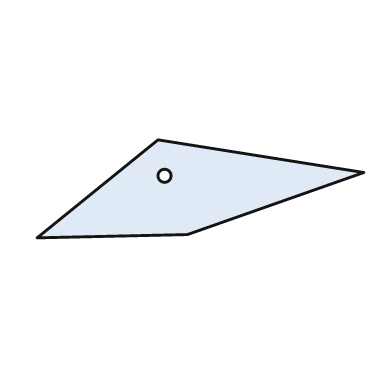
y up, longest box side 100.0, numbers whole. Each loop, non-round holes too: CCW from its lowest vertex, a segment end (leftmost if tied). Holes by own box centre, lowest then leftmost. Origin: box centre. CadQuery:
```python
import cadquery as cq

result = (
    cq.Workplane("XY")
    .moveTo(-50.0, -15.0)
    .lineTo(-4.0, -14.0)
    .lineTo(50.0, 5.0)
    .lineTo(-13.0, 15.0)
    .close()
    .moveTo(-11.0, 4.0)
    .circle(2.0)
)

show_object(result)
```